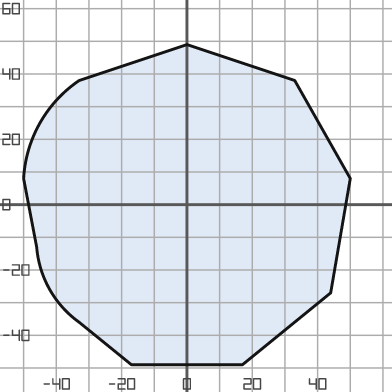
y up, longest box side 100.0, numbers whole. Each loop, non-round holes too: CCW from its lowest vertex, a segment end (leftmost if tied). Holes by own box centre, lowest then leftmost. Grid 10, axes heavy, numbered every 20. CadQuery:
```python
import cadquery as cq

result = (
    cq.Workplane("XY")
    .moveTo(-17.0, -49.0)
    .lineTo(17.0, -49.0)
    .lineTo(44.0, -27.0)
    .lineTo(50.0, 8.0)
    .lineTo(33.0, 38.0)
    .lineTo(0.0, 49.0)
    .lineTo(-33.0, 38.0)
    .threePointArc((-45.0, 25.0), (-50.0, 8.0))
    .lineTo(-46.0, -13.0)
    .threePointArc((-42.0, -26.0), (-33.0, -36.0))
    .close()
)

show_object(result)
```